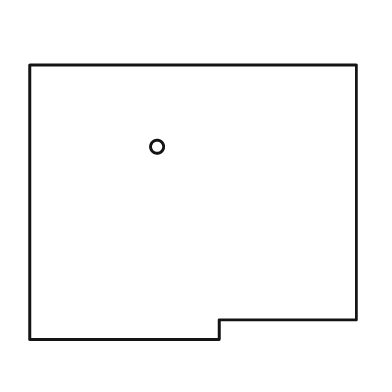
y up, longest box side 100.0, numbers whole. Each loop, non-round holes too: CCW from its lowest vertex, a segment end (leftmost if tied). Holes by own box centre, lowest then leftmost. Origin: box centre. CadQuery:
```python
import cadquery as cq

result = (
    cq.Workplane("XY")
    .moveTo(-50.0, -42.0)
    .lineTo(8.0, -42.0)
    .lineTo(8.0, -36.0)
    .lineTo(50.0, -36.0)
    .lineTo(50.0, 42.0)
    .lineTo(-50.0, 42.0)
    .close()
    .moveTo(-11.0, 17.0)
    .circle(2.0)
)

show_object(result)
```